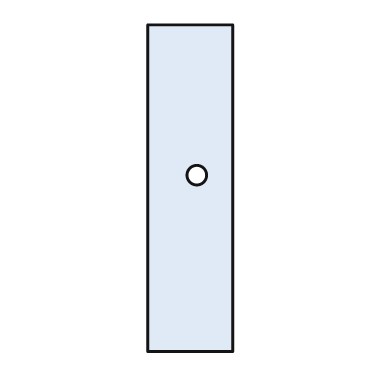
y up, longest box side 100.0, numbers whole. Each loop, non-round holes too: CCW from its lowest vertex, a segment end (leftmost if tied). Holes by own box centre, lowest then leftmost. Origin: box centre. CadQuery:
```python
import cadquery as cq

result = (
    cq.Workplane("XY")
    .moveTo(-13.0, -50.0)
    .lineTo(13.0, -50.0)
    .lineTo(13.0, 50.0)
    .lineTo(-13.0, 50.0)
    .close()
    .moveTo(2.0, 4.0)
    .circle(3.0)
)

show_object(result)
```